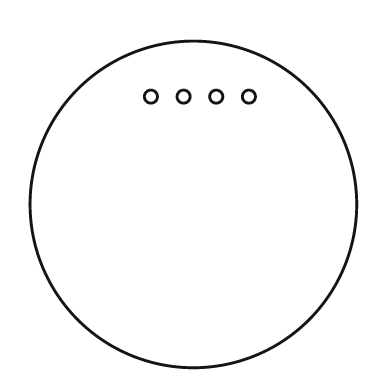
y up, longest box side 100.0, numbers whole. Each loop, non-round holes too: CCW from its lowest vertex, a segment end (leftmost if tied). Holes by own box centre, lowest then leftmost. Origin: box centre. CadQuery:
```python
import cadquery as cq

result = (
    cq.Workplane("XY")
    .moveTo(0.0, 0.0)
    .circle(50.0)
    .moveTo(-13.0, 33.0)
    .circle(2.0)
    .moveTo(-3.0, 33.0)
    .circle(2.0)
    .moveTo(7.0, 33.0)
    .circle(2.0)
    .moveTo(17.0, 33.0)
    .circle(2.0)
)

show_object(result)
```